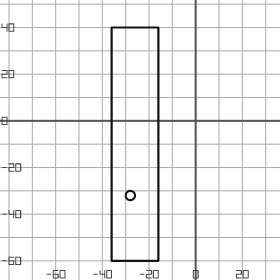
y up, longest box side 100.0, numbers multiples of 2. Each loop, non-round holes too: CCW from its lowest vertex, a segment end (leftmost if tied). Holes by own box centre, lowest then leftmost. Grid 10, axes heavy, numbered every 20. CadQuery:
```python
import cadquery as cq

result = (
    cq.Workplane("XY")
    .moveTo(-36.0, -60.0)
    .lineTo(-16.0, -60.0)
    .lineTo(-16.0, 40.0)
    .lineTo(-36.0, 40.0)
    .close()
    .moveTo(-28.0, -32.0)
    .circle(2.0)
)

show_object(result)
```